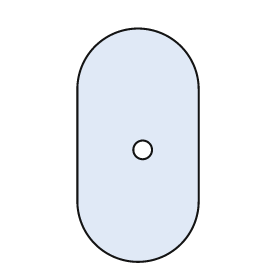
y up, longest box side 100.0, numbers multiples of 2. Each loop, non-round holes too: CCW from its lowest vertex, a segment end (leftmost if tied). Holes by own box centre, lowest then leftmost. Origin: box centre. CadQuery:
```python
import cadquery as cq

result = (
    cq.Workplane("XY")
    .moveTo(-26.0, -24.0)
    .threePointArc((0.0, -50.0), (26.0, -24.0))
    .lineTo(26.0, 24.0)
    .threePointArc((0.0, 50.0), (-26.0, 24.0))
    .close()
    .moveTo(2.0, -2.0)
    .circle(4.0)
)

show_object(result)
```